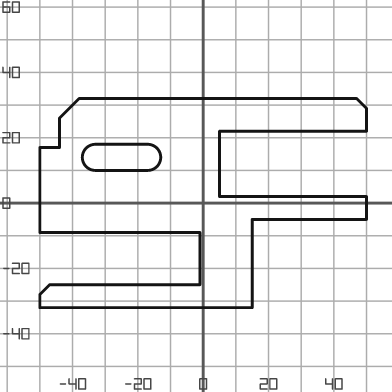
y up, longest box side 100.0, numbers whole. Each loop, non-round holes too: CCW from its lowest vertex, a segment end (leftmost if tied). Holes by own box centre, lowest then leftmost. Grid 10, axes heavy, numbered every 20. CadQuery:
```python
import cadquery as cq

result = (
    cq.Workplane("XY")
    .moveTo(-50.0, -32.0)
    .lineTo(15.0, -32.0)
    .lineTo(15.0, -5.0)
    .lineTo(50.0, -5.0)
    .lineTo(50.0, 2.0)
    .lineTo(5.0, 2.0)
    .lineTo(5.0, 22.0)
    .lineTo(50.0, 22.0)
    .lineTo(50.0, 29.0)
    .lineTo(47.0, 32.0)
    .lineTo(-38.0, 32.0)
    .lineTo(-44.0, 26.0)
    .lineTo(-44.0, 17.0)
    .lineTo(-50.0, 17.0)
    .lineTo(-50.0, -9.0)
    .lineTo(-1.0, -9.0)
    .lineTo(-1.0, -25.0)
    .lineTo(-47.0, -25.0)
    .lineTo(-50.0, -28.0)
    .close()
    .moveTo(-33.0, 10.0)
    .lineTo(-17.0, 10.0)
    .threePointArc((-13.0, 14.0), (-17.0, 18.0))
    .lineTo(-33.0, 18.0)
    .threePointArc((-37.0, 14.0), (-33.0, 10.0))
    .close()
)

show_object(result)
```